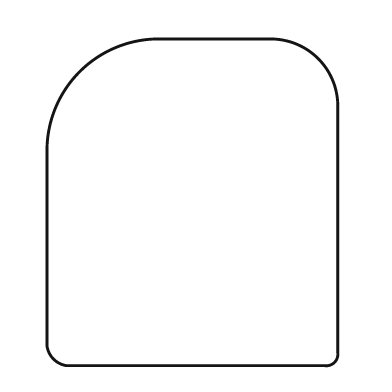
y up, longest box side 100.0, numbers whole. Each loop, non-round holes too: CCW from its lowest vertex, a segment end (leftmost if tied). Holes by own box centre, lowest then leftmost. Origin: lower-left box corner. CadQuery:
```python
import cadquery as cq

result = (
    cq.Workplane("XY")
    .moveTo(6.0, 0.0)
    .lineTo(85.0, 0.0)
    .threePointArc((88.0, 1.0), (89.0, 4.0))
    .lineTo(89.0, 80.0)
    .threePointArc((83.0, 94.0), (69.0, 100.0))
    .lineTo(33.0, 100.0)
    .threePointArc((10.0, 90.0), (0.0, 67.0))
    .lineTo(0.0, 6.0)
    .threePointArc((2.0, 2.0), (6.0, 0.0))
    .close()
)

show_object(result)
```